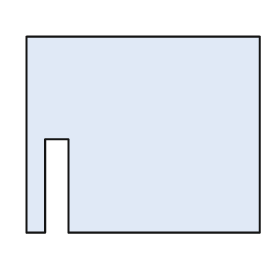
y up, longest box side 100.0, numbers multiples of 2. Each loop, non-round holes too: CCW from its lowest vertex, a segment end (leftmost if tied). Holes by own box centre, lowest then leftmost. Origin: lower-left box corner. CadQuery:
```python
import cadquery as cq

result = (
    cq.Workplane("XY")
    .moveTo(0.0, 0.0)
    .lineTo(8.0, 0.0)
    .lineTo(8.0, 40.0)
    .lineTo(18.0, 40.0)
    .lineTo(18.0, 0.0)
    .lineTo(100.0, 0.0)
    .lineTo(100.0, 84.0)
    .lineTo(0.0, 84.0)
    .close()
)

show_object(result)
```